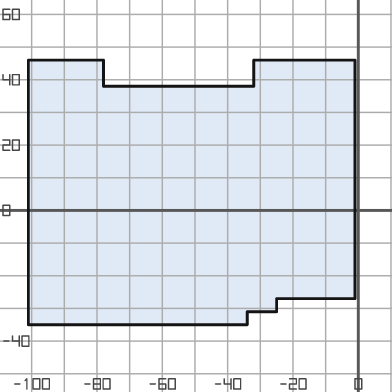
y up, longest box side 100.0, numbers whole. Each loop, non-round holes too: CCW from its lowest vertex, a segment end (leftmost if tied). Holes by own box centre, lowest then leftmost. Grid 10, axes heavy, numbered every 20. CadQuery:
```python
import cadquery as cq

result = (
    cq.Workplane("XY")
    .moveTo(-101.0, -35.0)
    .lineTo(-34.0, -35.0)
    .lineTo(-34.0, -31.0)
    .lineTo(-25.0, -31.0)
    .lineTo(-25.0, -27.0)
    .lineTo(-1.0, -27.0)
    .lineTo(-1.0, 46.0)
    .lineTo(-32.0, 46.0)
    .lineTo(-32.0, 38.0)
    .lineTo(-78.0, 38.0)
    .lineTo(-78.0, 46.0)
    .lineTo(-101.0, 46.0)
    .close()
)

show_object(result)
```